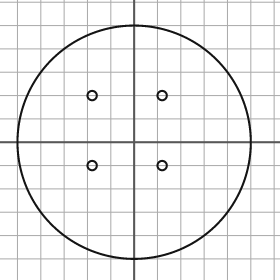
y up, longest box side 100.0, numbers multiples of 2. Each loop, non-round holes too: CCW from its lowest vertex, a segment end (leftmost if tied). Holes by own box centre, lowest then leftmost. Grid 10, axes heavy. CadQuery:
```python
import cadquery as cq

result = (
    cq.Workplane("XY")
    .moveTo(0.0, 0.0)
    .circle(50.0)
    .moveTo(-18.0, -10.0)
    .circle(2.0)
    .moveTo(12.0, -10.0)
    .circle(2.0)
    .moveTo(-18.0, 20.0)
    .circle(2.0)
    .moveTo(12.0, 20.0)
    .circle(2.0)
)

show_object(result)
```